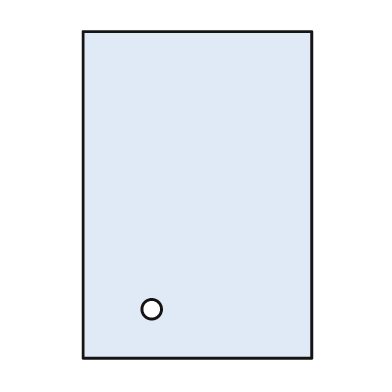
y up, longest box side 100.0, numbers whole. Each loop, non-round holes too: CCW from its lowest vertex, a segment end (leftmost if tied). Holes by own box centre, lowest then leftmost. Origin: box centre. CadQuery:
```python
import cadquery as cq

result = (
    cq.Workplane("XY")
    .moveTo(-35.0, -50.0)
    .lineTo(35.0, -50.0)
    .lineTo(35.0, 50.0)
    .lineTo(-35.0, 50.0)
    .close()
    .moveTo(-14.0, -35.0)
    .circle(3.0)
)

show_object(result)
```